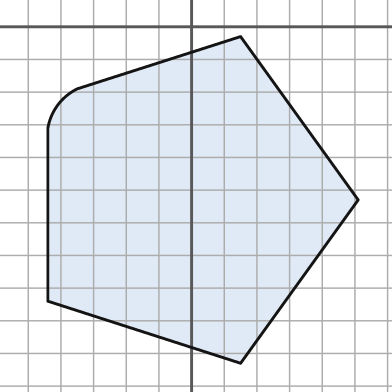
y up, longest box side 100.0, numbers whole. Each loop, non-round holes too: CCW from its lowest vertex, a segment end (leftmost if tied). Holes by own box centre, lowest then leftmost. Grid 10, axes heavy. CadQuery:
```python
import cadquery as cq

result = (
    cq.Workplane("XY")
    .moveTo(15.0, -103.0)
    .lineTo(51.0, -53.0)
    .lineTo(15.0, -3.0)
    .lineTo(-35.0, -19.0)
    .threePointArc((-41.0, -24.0), (-44.0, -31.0))
    .lineTo(-44.0, -84.0)
    .close()
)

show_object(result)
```